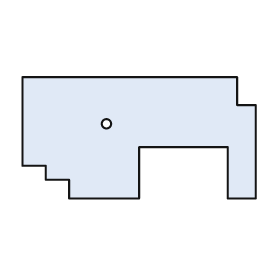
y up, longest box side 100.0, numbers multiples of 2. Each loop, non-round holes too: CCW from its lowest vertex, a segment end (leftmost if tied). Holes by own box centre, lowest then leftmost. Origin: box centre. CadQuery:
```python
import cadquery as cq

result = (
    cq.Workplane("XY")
    .moveTo(-30.0, -26.0)
    .lineTo(0.0, -26.0)
    .lineTo(0.0, -4.0)
    .lineTo(38.0, -4.0)
    .lineTo(38.0, -26.0)
    .lineTo(50.0, -26.0)
    .lineTo(50.0, 14.0)
    .lineTo(42.0, 14.0)
    .lineTo(42.0, 26.0)
    .lineTo(-50.0, 26.0)
    .lineTo(-50.0, -12.0)
    .lineTo(-40.0, -12.0)
    .lineTo(-40.0, -18.0)
    .lineTo(-30.0, -18.0)
    .close()
    .moveTo(-14.0, 6.0)
    .circle(2.0)
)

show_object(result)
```